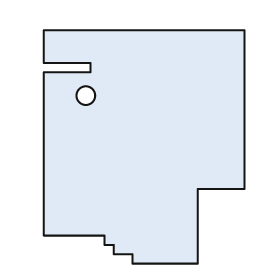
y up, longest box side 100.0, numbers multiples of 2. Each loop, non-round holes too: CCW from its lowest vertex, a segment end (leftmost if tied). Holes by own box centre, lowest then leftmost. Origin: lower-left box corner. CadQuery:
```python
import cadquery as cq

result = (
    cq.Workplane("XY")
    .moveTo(38.0, 0.0)
    .lineTo(66.0, 0.0)
    .lineTo(66.0, 32.0)
    .lineTo(86.0, 32.0)
    .lineTo(86.0, 100.0)
    .lineTo(0.0, 100.0)
    .lineTo(0.0, 86.0)
    .lineTo(20.0, 86.0)
    .lineTo(20.0, 82.0)
    .lineTo(0.0, 82.0)
    .lineTo(0.0, 12.0)
    .lineTo(26.0, 12.0)
    .lineTo(26.0, 8.0)
    .lineTo(30.0, 8.0)
    .lineTo(30.0, 4.0)
    .lineTo(38.0, 4.0)
    .close()
    .moveTo(18.0, 72.0)
    .circle(4.0)
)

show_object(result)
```